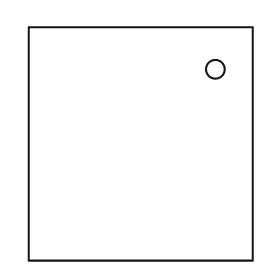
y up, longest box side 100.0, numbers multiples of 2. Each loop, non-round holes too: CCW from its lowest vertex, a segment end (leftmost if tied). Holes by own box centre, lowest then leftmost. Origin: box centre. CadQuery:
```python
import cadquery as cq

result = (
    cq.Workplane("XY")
    .moveTo(-48.0, -50.0)
    .lineTo(48.0, -50.0)
    .lineTo(48.0, 50.0)
    .lineTo(-48.0, 50.0)
    .close()
    .moveTo(32.0, 32.0)
    .circle(4.0)
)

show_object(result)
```